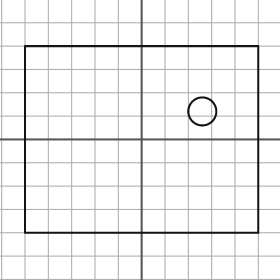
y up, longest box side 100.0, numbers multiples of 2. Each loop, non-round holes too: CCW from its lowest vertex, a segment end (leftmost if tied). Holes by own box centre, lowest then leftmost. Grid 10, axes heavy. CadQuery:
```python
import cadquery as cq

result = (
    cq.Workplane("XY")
    .moveTo(-50.0, -40.0)
    .lineTo(50.0, -40.0)
    .lineTo(50.0, 40.0)
    .lineTo(-50.0, 40.0)
    .close()
    .moveTo(26.0, 12.0)
    .circle(6.0)
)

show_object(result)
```